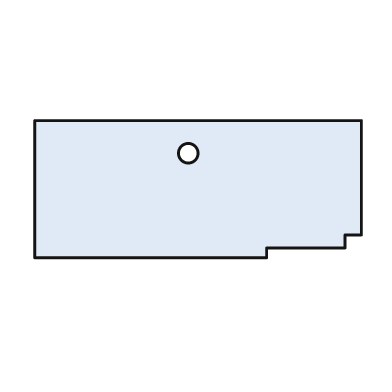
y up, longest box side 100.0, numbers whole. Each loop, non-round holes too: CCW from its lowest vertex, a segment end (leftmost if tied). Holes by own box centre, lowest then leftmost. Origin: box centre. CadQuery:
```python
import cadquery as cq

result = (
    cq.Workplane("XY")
    .moveTo(-50.0, -21.0)
    .lineTo(21.0, -21.0)
    .lineTo(21.0, -18.0)
    .lineTo(45.0, -18.0)
    .lineTo(45.0, -14.0)
    .lineTo(50.0, -14.0)
    .lineTo(50.0, 21.0)
    .lineTo(-50.0, 21.0)
    .close()
    .moveTo(-3.0, 11.0)
    .circle(3.0)
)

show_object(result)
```